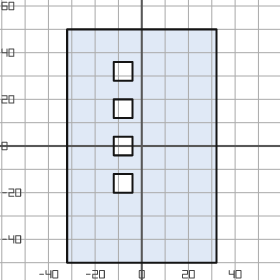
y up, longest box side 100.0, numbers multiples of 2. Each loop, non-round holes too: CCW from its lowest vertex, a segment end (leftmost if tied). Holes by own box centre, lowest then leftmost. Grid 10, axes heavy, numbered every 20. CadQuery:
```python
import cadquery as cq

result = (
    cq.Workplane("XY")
    .moveTo(-32.0, -50.0)
    .lineTo(32.0, -50.0)
    .lineTo(32.0, 50.0)
    .lineTo(-32.0, 50.0)
    .close()
    .moveTo(-12.0, -20.0)
    .lineTo(-4.0, -20.0)
    .lineTo(-4.0, -12.0)
    .lineTo(-12.0, -12.0)
    .close()
    .moveTo(-12.0, -4.0)
    .lineTo(-4.0, -4.0)
    .lineTo(-4.0, 4.0)
    .lineTo(-12.0, 4.0)
    .close()
    .moveTo(-12.0, 12.0)
    .lineTo(-4.0, 12.0)
    .lineTo(-4.0, 20.0)
    .lineTo(-12.0, 20.0)
    .close()
    .moveTo(-12.0, 28.0)
    .lineTo(-4.0, 28.0)
    .lineTo(-4.0, 36.0)
    .lineTo(-12.0, 36.0)
    .close()
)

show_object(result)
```